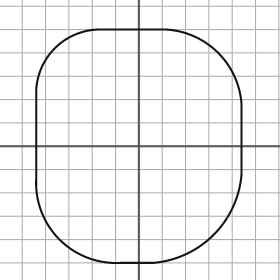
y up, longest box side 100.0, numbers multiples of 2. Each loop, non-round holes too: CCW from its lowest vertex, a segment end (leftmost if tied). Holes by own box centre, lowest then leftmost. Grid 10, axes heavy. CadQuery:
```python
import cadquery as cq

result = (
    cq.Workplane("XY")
    .moveTo(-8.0, -50.0)
    .lineTo(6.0, -50.0)
    .threePointArc((32.0, -38.0), (44.0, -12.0))
    .lineTo(44.0, 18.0)
    .threePointArc((34.0, 40.0), (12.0, 50.0))
    .lineTo(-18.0, 50.0)
    .threePointArc((-36.0, 42.0), (-44.0, 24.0))
    .lineTo(-44.0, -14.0)
    .threePointArc((-34.0, -40.0), (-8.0, -50.0))
    .close()
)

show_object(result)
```